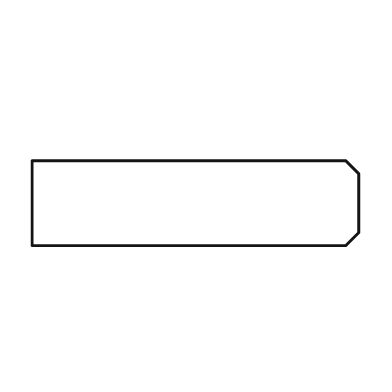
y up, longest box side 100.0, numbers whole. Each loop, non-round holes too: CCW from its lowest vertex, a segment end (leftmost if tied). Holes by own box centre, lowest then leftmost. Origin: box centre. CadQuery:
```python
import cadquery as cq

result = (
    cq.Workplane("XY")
    .moveTo(-50.0, -13.0)
    .lineTo(46.0, -13.0)
    .lineTo(50.0, -9.0)
    .lineTo(50.0, 9.0)
    .lineTo(46.0, 13.0)
    .lineTo(-50.0, 13.0)
    .close()
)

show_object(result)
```